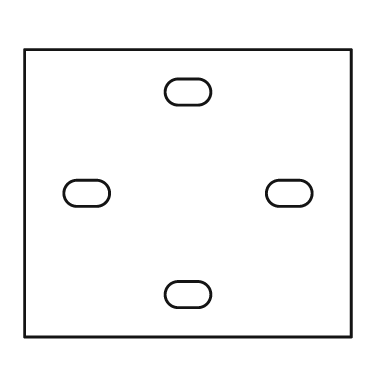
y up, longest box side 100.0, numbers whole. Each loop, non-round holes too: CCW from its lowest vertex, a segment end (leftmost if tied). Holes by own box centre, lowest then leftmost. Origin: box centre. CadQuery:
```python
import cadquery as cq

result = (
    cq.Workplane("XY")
    .moveTo(-50.0, -44.0)
    .lineTo(50.0, -44.0)
    .lineTo(50.0, 44.0)
    .lineTo(-50.0, 44.0)
    .close()
    .moveTo(-3.0, -35.0)
    .lineTo(3.0, -35.0)
    .threePointArc((7.0, -31.0), (3.0, -27.0))
    .lineTo(-3.0, -27.0)
    .threePointArc((-7.0, -31.0), (-3.0, -35.0))
    .close()
    .moveTo(-34.0, -4.0)
    .lineTo(-28.0, -4.0)
    .threePointArc((-24.0, 0.0), (-28.0, 4.0))
    .lineTo(-34.0, 4.0)
    .threePointArc((-38.0, 0.0), (-34.0, -4.0))
    .close()
    .moveTo(28.0, -4.0)
    .lineTo(34.0, -4.0)
    .threePointArc((38.0, 0.0), (34.0, 4.0))
    .lineTo(28.0, 4.0)
    .threePointArc((24.0, 0.0), (28.0, -4.0))
    .close()
    .moveTo(-3.0, 27.0)
    .lineTo(3.0, 27.0)
    .threePointArc((7.0, 31.0), (3.0, 35.0))
    .lineTo(-3.0, 35.0)
    .threePointArc((-7.0, 31.0), (-3.0, 27.0))
    .close()
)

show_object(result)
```